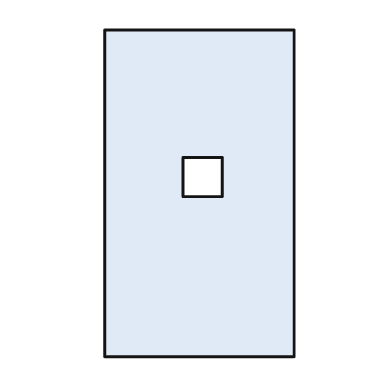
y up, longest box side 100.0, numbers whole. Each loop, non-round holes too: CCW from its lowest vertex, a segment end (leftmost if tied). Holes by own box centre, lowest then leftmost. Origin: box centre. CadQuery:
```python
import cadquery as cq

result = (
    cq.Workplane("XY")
    .moveTo(-29.0, -50.0)
    .lineTo(29.0, -50.0)
    .lineTo(29.0, 50.0)
    .lineTo(-29.0, 50.0)
    .close()
    .moveTo(-5.0, -1.0)
    .lineTo(7.0, -1.0)
    .lineTo(7.0, 11.0)
    .lineTo(-5.0, 11.0)
    .close()
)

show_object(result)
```